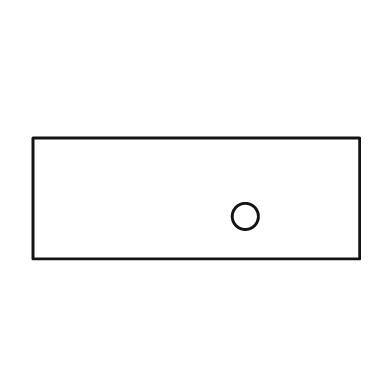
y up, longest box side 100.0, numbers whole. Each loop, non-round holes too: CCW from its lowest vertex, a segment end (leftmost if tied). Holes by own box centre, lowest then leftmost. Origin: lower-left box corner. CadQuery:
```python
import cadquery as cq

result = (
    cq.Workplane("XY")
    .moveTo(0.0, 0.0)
    .lineTo(100.0, 0.0)
    .lineTo(100.0, 37.0)
    .lineTo(0.0, 37.0)
    .close()
    .moveTo(65.0, 13.0)
    .circle(4.0)
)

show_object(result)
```